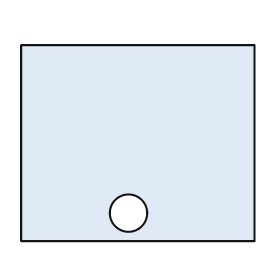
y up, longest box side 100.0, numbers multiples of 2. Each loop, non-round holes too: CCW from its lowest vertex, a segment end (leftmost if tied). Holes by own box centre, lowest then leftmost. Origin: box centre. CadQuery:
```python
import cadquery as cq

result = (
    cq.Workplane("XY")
    .moveTo(-50.0, -42.0)
    .lineTo(50.0, -42.0)
    .lineTo(50.0, 42.0)
    .lineTo(-50.0, 42.0)
    .close()
    .moveTo(-4.0, -30.0)
    .circle(8.0)
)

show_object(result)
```